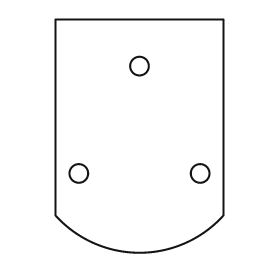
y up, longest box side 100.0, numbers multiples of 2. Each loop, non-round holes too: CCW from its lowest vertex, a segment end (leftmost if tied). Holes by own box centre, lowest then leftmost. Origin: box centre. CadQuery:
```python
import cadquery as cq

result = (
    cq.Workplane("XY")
    .moveTo(-36.0, -34.0)
    .threePointArc((0.0, -50.0), (36.0, -34.0))
    .lineTo(36.0, 50.0)
    .lineTo(-36.0, 50.0)
    .close()
    .moveTo(-26.0, -16.0)
    .circle(4.0)
    .moveTo(26.0, -16.0)
    .circle(4.0)
    .moveTo(0.0, 30.0)
    .circle(4.0)
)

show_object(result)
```